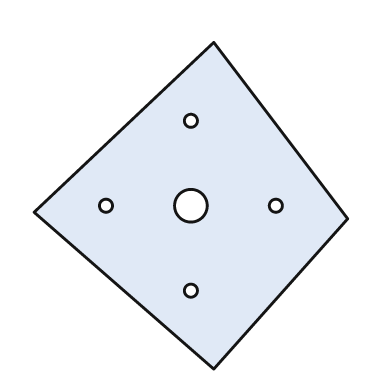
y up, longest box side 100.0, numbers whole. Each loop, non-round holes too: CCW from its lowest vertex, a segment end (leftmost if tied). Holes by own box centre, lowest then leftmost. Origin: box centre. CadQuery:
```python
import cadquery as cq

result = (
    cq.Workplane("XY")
    .moveTo(7.0, -50.0)
    .lineTo(48.0, -4.0)
    .lineTo(7.0, 50.0)
    .lineTo(-48.0, -2.0)
    .close()
    .moveTo(0.0, -26.0)
    .circle(2.0)
    .moveTo(-26.0, 0.0)
    .circle(2.0)
    .moveTo(0.0, 0.0)
    .circle(5.0)
    .moveTo(26.0, 0.0)
    .circle(2.0)
    .moveTo(0.0, 26.0)
    .circle(2.0)
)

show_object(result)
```